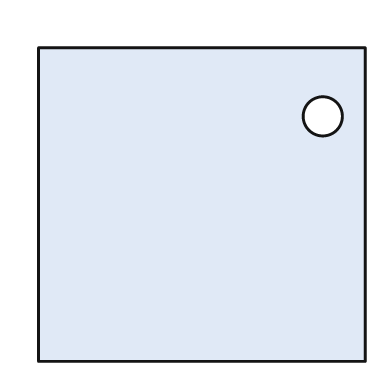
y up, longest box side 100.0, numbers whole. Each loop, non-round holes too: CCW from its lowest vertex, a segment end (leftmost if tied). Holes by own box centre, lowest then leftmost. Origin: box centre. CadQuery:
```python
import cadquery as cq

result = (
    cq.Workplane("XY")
    .moveTo(-50.0, -48.0)
    .lineTo(50.0, -48.0)
    .lineTo(50.0, 48.0)
    .lineTo(-50.0, 48.0)
    .close()
    .moveTo(37.0, 27.0)
    .circle(6.0)
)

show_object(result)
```